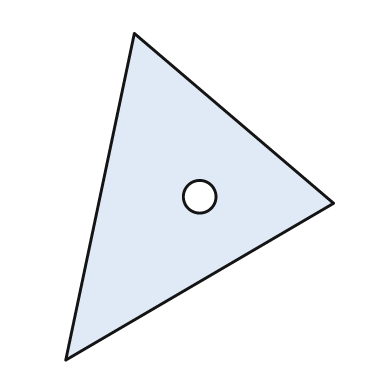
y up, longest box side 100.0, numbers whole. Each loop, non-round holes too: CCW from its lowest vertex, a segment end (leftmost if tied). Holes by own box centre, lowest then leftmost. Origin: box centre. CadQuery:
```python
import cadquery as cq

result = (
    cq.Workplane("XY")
    .moveTo(-41.0, -50.0)
    .lineTo(41.0, -2.0)
    .lineTo(-20.0, 50.0)
    .close()
    .moveTo(0.0, 0.0)
    .circle(5.0)
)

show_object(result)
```